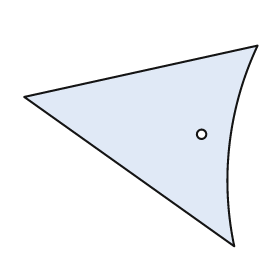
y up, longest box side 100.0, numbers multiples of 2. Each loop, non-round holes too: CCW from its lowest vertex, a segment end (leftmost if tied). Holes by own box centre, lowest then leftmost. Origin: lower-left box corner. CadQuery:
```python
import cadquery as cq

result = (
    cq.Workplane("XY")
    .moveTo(90.0, 0.0)
    .threePointArc((88.0, 44.0), (100.0, 86.0))
    .lineTo(0.0, 64.0)
    .close()
    .moveTo(76.0, 48.0)
    .circle(2.0)
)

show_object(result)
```